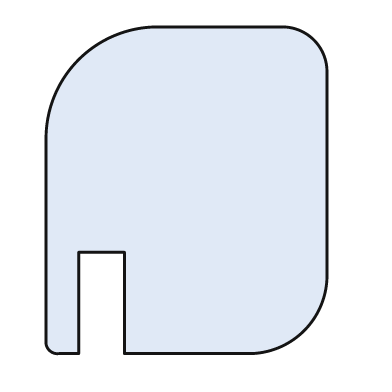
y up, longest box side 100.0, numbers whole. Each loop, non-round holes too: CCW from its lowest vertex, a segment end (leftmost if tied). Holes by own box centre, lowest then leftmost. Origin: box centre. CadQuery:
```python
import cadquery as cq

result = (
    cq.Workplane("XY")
    .moveTo(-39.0, -50.0)
    .lineTo(-33.0, -50.0)
    .lineTo(-33.0, -19.0)
    .lineTo(-19.0, -19.0)
    .lineTo(-19.0, -50.0)
    .lineTo(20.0, -50.0)
    .threePointArc((36.0, -43.0), (43.0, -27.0))
    .lineTo(43.0, 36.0)
    .threePointArc((39.0, 46.0), (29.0, 50.0))
    .lineTo(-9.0, 50.0)
    .threePointArc((-33.0, 40.0), (-43.0, 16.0))
    .lineTo(-43.0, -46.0)
    .threePointArc((-42.0, -49.0), (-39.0, -50.0))
    .close()
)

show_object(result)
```